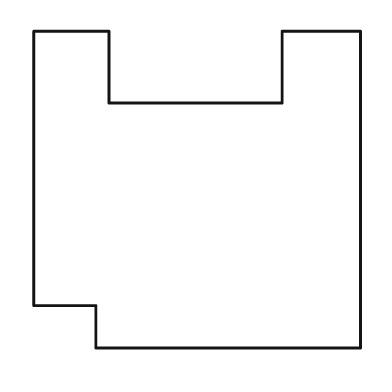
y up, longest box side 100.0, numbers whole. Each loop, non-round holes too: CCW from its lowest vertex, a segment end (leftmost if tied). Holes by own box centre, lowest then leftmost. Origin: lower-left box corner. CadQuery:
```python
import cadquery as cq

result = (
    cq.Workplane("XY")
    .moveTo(19.0, 0.0)
    .lineTo(100.0, 0.0)
    .lineTo(100.0, 97.0)
    .lineTo(76.0, 97.0)
    .lineTo(76.0, 75.0)
    .lineTo(23.0, 75.0)
    .lineTo(23.0, 97.0)
    .lineTo(0.0, 97.0)
    .lineTo(0.0, 13.0)
    .lineTo(19.0, 13.0)
    .close()
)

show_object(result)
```